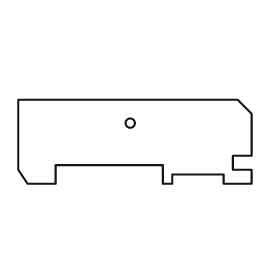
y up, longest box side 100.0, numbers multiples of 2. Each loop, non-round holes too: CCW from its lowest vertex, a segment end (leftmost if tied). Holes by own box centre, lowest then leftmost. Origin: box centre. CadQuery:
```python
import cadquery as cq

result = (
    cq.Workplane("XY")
    .moveTo(-46.0, -18.0)
    .lineTo(-34.0, -18.0)
    .lineTo(-34.0, -10.0)
    .lineTo(12.0, -10.0)
    .lineTo(12.0, -18.0)
    .lineTo(16.0, -18.0)
    .lineTo(16.0, -14.0)
    .lineTo(38.0, -14.0)
    .lineTo(38.0, -18.0)
    .lineTo(50.0, -18.0)
    .lineTo(50.0, -12.0)
    .lineTo(42.0, -12.0)
    .lineTo(42.0, -6.0)
    .lineTo(50.0, -6.0)
    .lineTo(50.0, 12.0)
    .lineTo(44.0, 18.0)
    .lineTo(-50.0, 18.0)
    .lineTo(-50.0, -12.0)
    .close()
    .moveTo(-2.0, 8.0)
    .circle(2.0)
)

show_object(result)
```